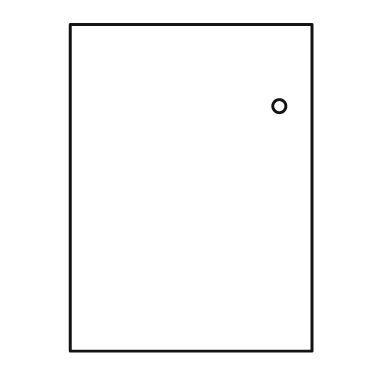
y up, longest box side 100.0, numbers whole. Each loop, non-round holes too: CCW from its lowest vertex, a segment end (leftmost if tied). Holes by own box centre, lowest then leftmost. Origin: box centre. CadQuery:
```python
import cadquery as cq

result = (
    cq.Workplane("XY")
    .moveTo(-37.0, -50.0)
    .lineTo(37.0, -50.0)
    .lineTo(37.0, 50.0)
    .lineTo(-37.0, 50.0)
    .close()
    .moveTo(27.0, 25.0)
    .circle(2.0)
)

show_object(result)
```